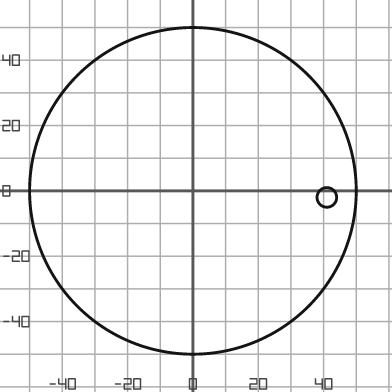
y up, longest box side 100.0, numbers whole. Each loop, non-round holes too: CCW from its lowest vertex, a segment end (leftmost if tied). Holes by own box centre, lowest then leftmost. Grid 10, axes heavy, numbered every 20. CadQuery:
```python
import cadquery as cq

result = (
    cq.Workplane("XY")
    .moveTo(0.0, 0.0)
    .circle(50.0)
    .moveTo(41.0, -2.0)
    .circle(3.0)
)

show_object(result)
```